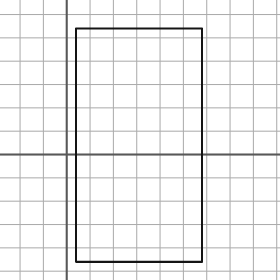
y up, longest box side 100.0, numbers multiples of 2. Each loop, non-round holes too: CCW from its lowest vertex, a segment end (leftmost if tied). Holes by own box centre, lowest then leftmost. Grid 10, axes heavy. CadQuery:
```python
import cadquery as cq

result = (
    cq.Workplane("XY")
    .moveTo(4.0, -46.0)
    .lineTo(58.0, -46.0)
    .lineTo(58.0, 54.0)
    .lineTo(4.0, 54.0)
    .close()
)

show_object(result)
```